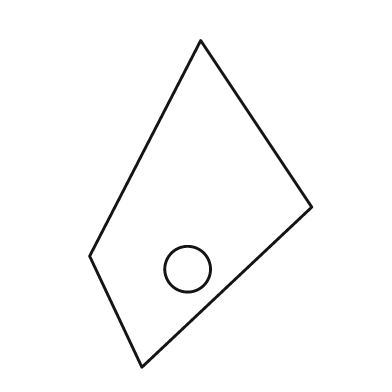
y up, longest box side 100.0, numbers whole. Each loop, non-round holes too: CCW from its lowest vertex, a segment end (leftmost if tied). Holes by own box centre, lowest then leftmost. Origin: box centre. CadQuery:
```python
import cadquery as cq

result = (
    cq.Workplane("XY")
    .moveTo(-18.0, -50.0)
    .lineTo(34.0, -1.0)
    .lineTo(0.0, 50.0)
    .lineTo(-34.0, -16.0)
    .close()
    .moveTo(-4.0, -20.0)
    .circle(7.0)
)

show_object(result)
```